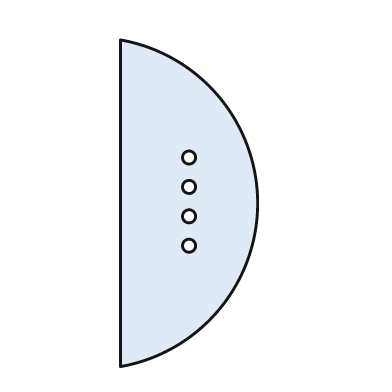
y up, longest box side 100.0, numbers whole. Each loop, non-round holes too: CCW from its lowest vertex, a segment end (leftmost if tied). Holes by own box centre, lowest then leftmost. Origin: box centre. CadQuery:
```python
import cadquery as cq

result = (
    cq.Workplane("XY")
    .moveTo(-21.0, -50.0)
    .threePointArc((21.0, 0.0), (-21.0, 50.0))
    .close()
    .moveTo(0.0, -13.0)
    .circle(2.0)
    .moveTo(0.0, -4.0)
    .circle(2.0)
    .moveTo(0.0, 5.0)
    .circle(2.0)
    .moveTo(0.0, 14.0)
    .circle(2.0)
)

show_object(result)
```